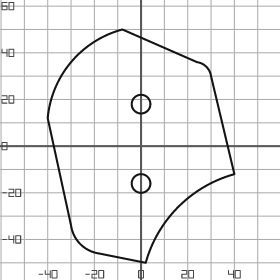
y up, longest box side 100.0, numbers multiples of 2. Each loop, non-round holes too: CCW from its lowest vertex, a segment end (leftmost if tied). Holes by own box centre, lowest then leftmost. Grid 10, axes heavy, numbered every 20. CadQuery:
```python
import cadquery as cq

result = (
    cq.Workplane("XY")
    .moveTo(2.0, -50.0)
    .threePointArc((16.0, -26.0), (40.0, -12.0))
    .lineTo(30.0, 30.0)
    .threePointArc((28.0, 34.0), (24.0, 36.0))
    .lineTo(-8.0, 50.0)
    .threePointArc((-30.0, 36.0), (-40.0, 12.0))
    .lineTo(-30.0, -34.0)
    .threePointArc((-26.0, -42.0), (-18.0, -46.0))
    .close()
    .moveTo(0.0, -16.0)
    .circle(4.0)
    .moveTo(0.0, 18.0)
    .circle(4.0)
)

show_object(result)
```